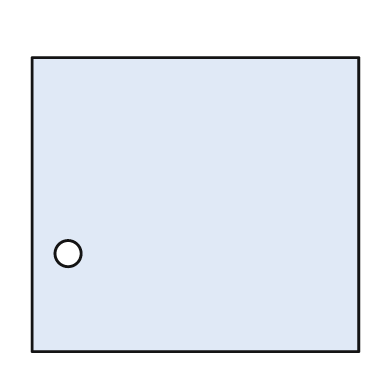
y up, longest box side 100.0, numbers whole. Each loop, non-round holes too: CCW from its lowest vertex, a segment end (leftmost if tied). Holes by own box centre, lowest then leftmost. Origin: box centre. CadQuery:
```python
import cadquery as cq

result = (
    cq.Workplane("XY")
    .moveTo(-50.0, -45.0)
    .lineTo(50.0, -45.0)
    .lineTo(50.0, 45.0)
    .lineTo(-50.0, 45.0)
    .close()
    .moveTo(-39.0, -15.0)
    .circle(4.0)
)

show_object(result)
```